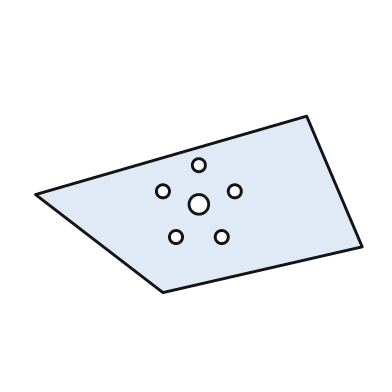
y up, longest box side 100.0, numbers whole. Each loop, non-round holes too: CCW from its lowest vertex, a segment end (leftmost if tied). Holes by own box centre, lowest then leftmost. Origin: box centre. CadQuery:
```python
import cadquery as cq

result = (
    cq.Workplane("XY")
    .moveTo(-11.0, -27.0)
    .lineTo(50.0, -13.0)
    .lineTo(33.0, 27.0)
    .lineTo(-50.0, 3.0)
    .close()
    .moveTo(-7.0, -10.0)
    .circle(2.0)
    .moveTo(7.0, -10.0)
    .circle(2.0)
    .moveTo(0.0, 0.0)
    .circle(3.0)
    .moveTo(-11.0, 4.0)
    .circle(2.0)
    .moveTo(11.0, 4.0)
    .circle(2.0)
    .moveTo(0.0, 12.0)
    .circle(2.0)
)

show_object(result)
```